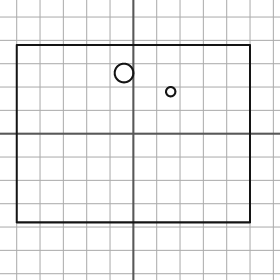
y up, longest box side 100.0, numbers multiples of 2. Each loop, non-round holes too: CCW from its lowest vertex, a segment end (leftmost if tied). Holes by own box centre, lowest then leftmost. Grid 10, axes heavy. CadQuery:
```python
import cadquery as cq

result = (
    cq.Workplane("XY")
    .moveTo(-50.0, -38.0)
    .lineTo(50.0, -38.0)
    .lineTo(50.0, 38.0)
    .lineTo(-50.0, 38.0)
    .close()
    .moveTo(16.0, 18.0)
    .circle(2.0)
    .moveTo(-4.0, 26.0)
    .circle(4.0)
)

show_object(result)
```